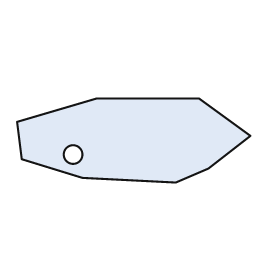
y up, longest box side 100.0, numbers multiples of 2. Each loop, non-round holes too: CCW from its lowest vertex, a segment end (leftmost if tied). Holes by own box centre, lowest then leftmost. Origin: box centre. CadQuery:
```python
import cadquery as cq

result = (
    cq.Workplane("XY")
    .moveTo(18.0, -18.0)
    .lineTo(32.0, -12.0)
    .lineTo(50.0, 2.0)
    .lineTo(28.0, 18.0)
    .lineTo(-16.0, 18.0)
    .lineTo(-50.0, 8.0)
    .lineTo(-48.0, -8.0)
    .lineTo(-22.0, -16.0)
    .close()
    .moveTo(-26.0, -6.0)
    .circle(4.0)
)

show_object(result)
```